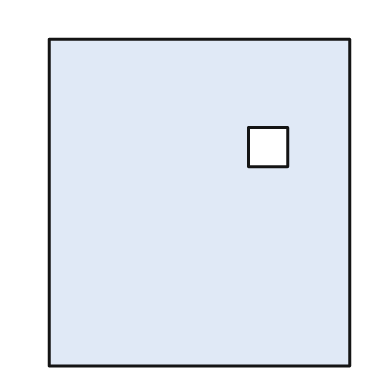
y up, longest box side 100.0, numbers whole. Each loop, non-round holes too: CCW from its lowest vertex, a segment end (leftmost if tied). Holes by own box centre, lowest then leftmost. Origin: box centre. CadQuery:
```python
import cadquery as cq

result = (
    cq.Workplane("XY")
    .moveTo(-46.0, -50.0)
    .lineTo(46.0, -50.0)
    .lineTo(46.0, 50.0)
    .lineTo(-46.0, 50.0)
    .close()
    .moveTo(15.0, 11.0)
    .lineTo(27.0, 11.0)
    .lineTo(27.0, 23.0)
    .lineTo(15.0, 23.0)
    .close()
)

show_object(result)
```